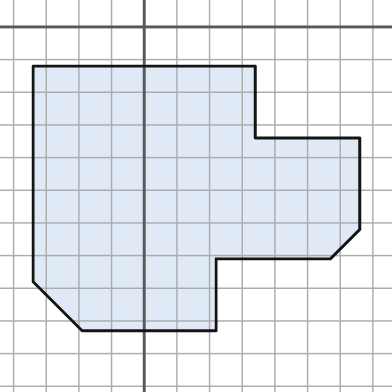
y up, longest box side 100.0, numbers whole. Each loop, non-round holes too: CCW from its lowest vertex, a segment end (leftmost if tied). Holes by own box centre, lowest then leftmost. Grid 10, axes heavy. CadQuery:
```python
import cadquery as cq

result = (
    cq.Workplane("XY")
    .moveTo(-19.0, -93.0)
    .lineTo(22.0, -93.0)
    .lineTo(22.0, -71.0)
    .lineTo(57.0, -71.0)
    .lineTo(66.0, -62.0)
    .lineTo(66.0, -34.0)
    .lineTo(34.0, -34.0)
    .lineTo(34.0, -12.0)
    .lineTo(-34.0, -12.0)
    .lineTo(-34.0, -78.0)
    .close()
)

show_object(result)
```